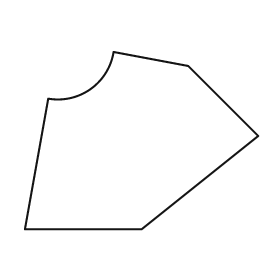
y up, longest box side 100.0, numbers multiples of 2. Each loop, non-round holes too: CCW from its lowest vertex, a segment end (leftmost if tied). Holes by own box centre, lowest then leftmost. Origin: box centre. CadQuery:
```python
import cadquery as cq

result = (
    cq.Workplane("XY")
    .moveTo(-50.0, -38.0)
    .lineTo(0.0, -38.0)
    .lineTo(50.0, 2.0)
    .lineTo(20.0, 32.0)
    .lineTo(-12.0, 38.0)
    .threePointArc((-22.0, 22.0), (-40.0, 18.0))
    .close()
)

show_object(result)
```